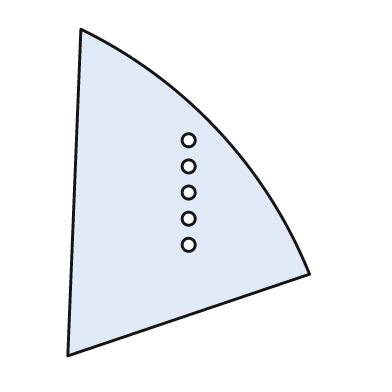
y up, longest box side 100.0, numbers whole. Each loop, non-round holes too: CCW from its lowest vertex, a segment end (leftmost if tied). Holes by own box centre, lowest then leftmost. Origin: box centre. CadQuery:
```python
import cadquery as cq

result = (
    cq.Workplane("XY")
    .moveTo(-37.0, -50.0)
    .lineTo(37.0, -25.0)
    .threePointArc((9.0, 19.0), (-33.0, 50.0))
    .close()
    .moveTo(0.0, -16.0)
    .circle(2.0)
    .moveTo(0.0, -8.0)
    .circle(2.0)
    .moveTo(0.0, 0.0)
    .circle(2.0)
    .moveTo(0.0, 8.0)
    .circle(2.0)
    .moveTo(0.0, 16.0)
    .circle(2.0)
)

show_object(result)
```